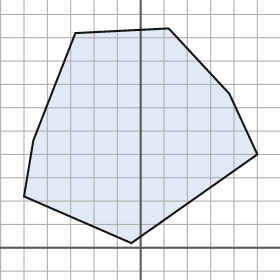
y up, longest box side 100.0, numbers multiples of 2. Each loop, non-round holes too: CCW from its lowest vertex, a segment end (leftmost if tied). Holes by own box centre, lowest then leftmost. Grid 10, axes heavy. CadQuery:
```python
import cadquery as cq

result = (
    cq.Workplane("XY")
    .moveTo(-4.0, 2.0)
    .lineTo(50.0, 40.0)
    .lineTo(38.0, 66.0)
    .lineTo(12.0, 94.0)
    .lineTo(-28.0, 92.0)
    .lineTo(-46.0, 46.0)
    .lineTo(-50.0, 22.0)
    .close()
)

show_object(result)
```